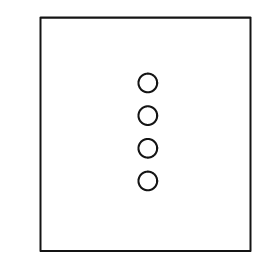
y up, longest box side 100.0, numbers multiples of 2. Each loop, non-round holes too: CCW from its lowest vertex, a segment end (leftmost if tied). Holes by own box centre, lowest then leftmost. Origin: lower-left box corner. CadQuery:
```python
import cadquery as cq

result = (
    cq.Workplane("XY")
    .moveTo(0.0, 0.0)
    .lineTo(90.0, 0.0)
    .lineTo(90.0, 100.0)
    .lineTo(0.0, 100.0)
    .close()
    .moveTo(46.0, 30.0)
    .circle(4.0)
    .moveTo(46.0, 44.0)
    .circle(4.0)
    .moveTo(46.0, 58.0)
    .circle(4.0)
    .moveTo(46.0, 72.0)
    .circle(4.0)
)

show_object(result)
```